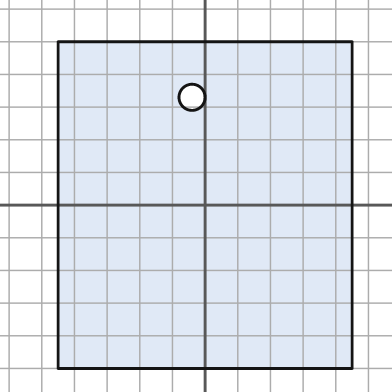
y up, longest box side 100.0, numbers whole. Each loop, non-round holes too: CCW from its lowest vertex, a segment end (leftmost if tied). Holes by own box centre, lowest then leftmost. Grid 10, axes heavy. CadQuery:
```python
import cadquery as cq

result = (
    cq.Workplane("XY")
    .moveTo(-45.0, -50.0)
    .lineTo(45.0, -50.0)
    .lineTo(45.0, 50.0)
    .lineTo(-45.0, 50.0)
    .close()
    .moveTo(-4.0, 33.0)
    .circle(4.0)
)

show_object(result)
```